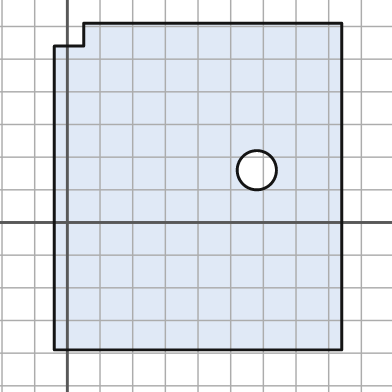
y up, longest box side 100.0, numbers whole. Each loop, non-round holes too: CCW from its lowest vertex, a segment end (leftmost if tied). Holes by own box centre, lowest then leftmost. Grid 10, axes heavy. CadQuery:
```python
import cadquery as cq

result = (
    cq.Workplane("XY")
    .moveTo(-4.0, -39.0)
    .lineTo(84.0, -39.0)
    .lineTo(84.0, 61.0)
    .lineTo(5.0, 61.0)
    .lineTo(5.0, 54.0)
    .lineTo(-4.0, 54.0)
    .close()
    .moveTo(58.0, 16.0)
    .circle(6.0)
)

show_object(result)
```